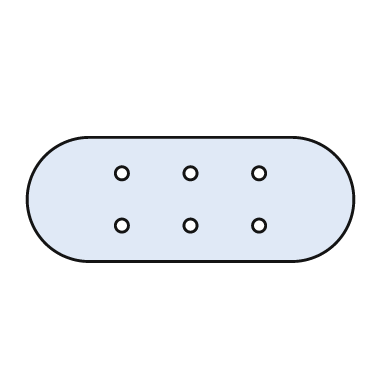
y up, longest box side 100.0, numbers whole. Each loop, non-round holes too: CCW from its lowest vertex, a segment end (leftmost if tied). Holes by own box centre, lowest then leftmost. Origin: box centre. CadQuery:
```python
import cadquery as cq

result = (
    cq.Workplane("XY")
    .moveTo(-31.0, -19.0)
    .lineTo(31.0, -19.0)
    .threePointArc((50.0, 0.0), (31.0, 19.0))
    .lineTo(-31.0, 19.0)
    .threePointArc((-50.0, 0.0), (-31.0, -19.0))
    .close()
    .moveTo(-21.0, -8.0)
    .circle(2.0)
    .moveTo(0.0, -8.0)
    .circle(2.0)
    .moveTo(21.0, -8.0)
    .circle(2.0)
    .moveTo(-21.0, 8.0)
    .circle(2.0)
    .moveTo(0.0, 8.0)
    .circle(2.0)
    .moveTo(21.0, 8.0)
    .circle(2.0)
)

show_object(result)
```